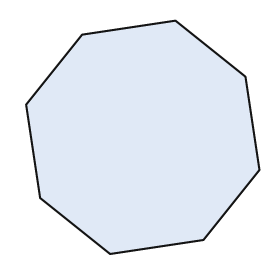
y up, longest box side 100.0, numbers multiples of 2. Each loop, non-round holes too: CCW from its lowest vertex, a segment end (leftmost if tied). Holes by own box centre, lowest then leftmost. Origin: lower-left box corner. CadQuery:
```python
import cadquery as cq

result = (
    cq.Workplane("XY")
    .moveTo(36.0, 0.0)
    .lineTo(76.0, 6.0)
    .lineTo(100.0, 36.0)
    .lineTo(94.0, 76.0)
    .lineTo(64.0, 100.0)
    .lineTo(24.0, 94.0)
    .lineTo(0.0, 64.0)
    .lineTo(6.0, 24.0)
    .close()
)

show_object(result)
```